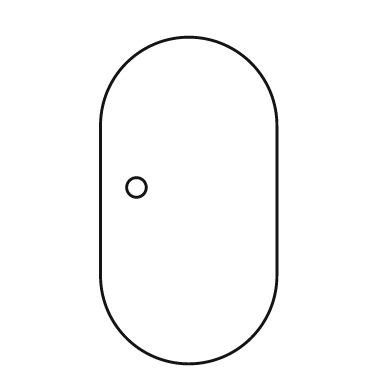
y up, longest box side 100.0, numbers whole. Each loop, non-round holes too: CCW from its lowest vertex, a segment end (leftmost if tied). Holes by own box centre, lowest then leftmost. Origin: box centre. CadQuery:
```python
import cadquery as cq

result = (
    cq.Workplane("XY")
    .moveTo(-27.0, -23.0)
    .threePointArc((0.0, -50.0), (27.0, -23.0))
    .lineTo(27.0, 23.0)
    .threePointArc((0.0, 50.0), (-27.0, 23.0))
    .close()
    .moveTo(-16.0, 4.0)
    .circle(3.0)
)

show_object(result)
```